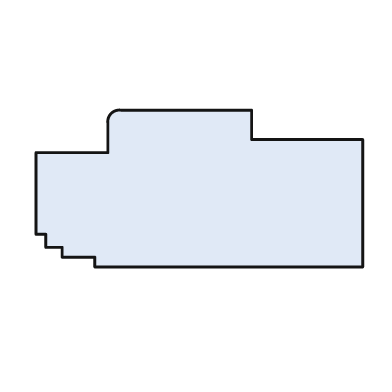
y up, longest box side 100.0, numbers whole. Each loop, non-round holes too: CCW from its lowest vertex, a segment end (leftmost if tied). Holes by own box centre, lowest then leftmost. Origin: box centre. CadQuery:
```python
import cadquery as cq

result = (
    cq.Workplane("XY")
    .moveTo(-32.0, -24.0)
    .lineTo(50.0, -24.0)
    .lineTo(50.0, 15.0)
    .lineTo(16.0, 15.0)
    .lineTo(16.0, 24.0)
    .lineTo(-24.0, 24.0)
    .threePointArc((-27.0, 23.0), (-28.0, 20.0))
    .lineTo(-28.0, 11.0)
    .lineTo(-50.0, 11.0)
    .lineTo(-50.0, -14.0)
    .lineTo(-47.0, -14.0)
    .lineTo(-47.0, -18.0)
    .lineTo(-42.0, -18.0)
    .lineTo(-42.0, -21.0)
    .lineTo(-32.0, -21.0)
    .close()
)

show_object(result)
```